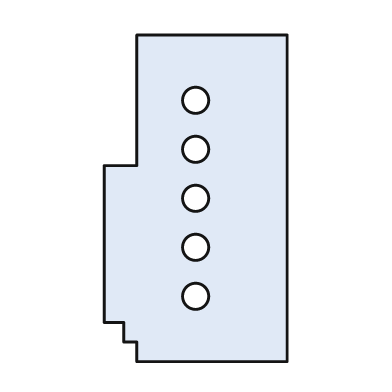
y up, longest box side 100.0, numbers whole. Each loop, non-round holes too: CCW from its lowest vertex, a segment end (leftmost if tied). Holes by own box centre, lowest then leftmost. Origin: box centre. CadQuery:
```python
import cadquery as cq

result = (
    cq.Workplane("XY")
    .moveTo(-18.0, -50.0)
    .lineTo(28.0, -50.0)
    .lineTo(28.0, 50.0)
    .lineTo(-18.0, 50.0)
    .lineTo(-18.0, 10.0)
    .lineTo(-28.0, 10.0)
    .lineTo(-28.0, -38.0)
    .lineTo(-22.0, -38.0)
    .lineTo(-22.0, -44.0)
    .lineTo(-18.0, -44.0)
    .close()
    .moveTo(0.0, -30.0)
    .circle(4.0)
    .moveTo(0.0, -15.0)
    .circle(4.0)
    .moveTo(0.0, 0.0)
    .circle(4.0)
    .moveTo(0.0, 15.0)
    .circle(4.0)
    .moveTo(0.0, 30.0)
    .circle(4.0)
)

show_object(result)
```